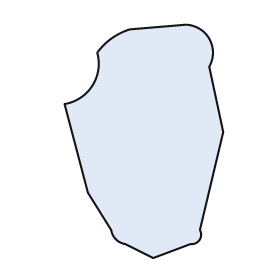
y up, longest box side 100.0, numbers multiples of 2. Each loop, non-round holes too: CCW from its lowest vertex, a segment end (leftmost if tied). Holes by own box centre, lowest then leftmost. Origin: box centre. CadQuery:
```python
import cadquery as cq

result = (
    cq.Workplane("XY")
    .moveTo(4.0, -50.0)
    .lineTo(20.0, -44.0)
    .threePointArc((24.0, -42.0), (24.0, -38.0))
    .lineTo(34.0, 4.0)
    .lineTo(28.0, 32.0)
    .threePointArc((28.0, 44.0), (18.0, 50.0))
    .lineTo(-6.0, 48.0)
    .threePointArc((-14.0, 44.0), (-20.0, 38.0))
    .threePointArc((-22.0, 24.0), (-34.0, 16.0))
    .lineTo(-24.0, -22.0)
    .lineTo(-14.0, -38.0)
    .threePointArc((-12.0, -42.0), (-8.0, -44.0))
    .close()
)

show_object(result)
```